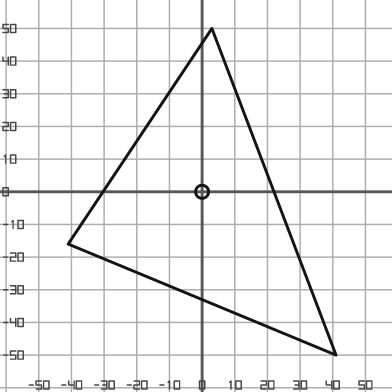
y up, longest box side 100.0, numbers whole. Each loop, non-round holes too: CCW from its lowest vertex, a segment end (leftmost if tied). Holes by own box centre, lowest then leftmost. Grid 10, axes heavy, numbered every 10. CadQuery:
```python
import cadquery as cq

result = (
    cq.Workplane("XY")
    .moveTo(41.0, -50.0)
    .lineTo(3.0, 50.0)
    .lineTo(-41.0, -16.0)
    .close()
    .moveTo(0.0, 0.0)
    .circle(2.0)
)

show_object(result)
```